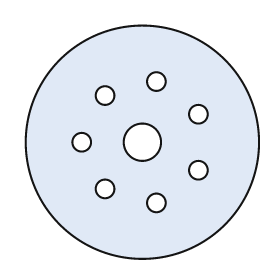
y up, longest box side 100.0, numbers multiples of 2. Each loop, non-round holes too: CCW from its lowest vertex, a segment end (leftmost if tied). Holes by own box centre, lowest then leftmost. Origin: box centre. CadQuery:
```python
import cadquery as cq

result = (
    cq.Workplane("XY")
    .moveTo(0.0, 0.0)
    .circle(50.0)
    .moveTo(6.0, -26.0)
    .circle(4.0)
    .moveTo(-16.0, -20.0)
    .circle(4.0)
    .moveTo(24.0, -12.0)
    .circle(4.0)
    .moveTo(-26.0, 0.0)
    .circle(4.0)
    .moveTo(0.0, 0.0)
    .circle(8.0)
    .moveTo(24.0, 12.0)
    .circle(4.0)
    .moveTo(-16.0, 20.0)
    .circle(4.0)
    .moveTo(6.0, 26.0)
    .circle(4.0)
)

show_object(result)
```